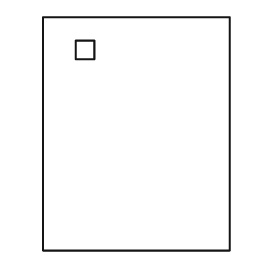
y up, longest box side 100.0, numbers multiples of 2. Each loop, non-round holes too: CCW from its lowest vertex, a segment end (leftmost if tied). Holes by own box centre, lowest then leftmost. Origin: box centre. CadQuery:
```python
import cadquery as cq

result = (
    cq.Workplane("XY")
    .moveTo(-40.0, -50.0)
    .lineTo(40.0, -50.0)
    .lineTo(40.0, 50.0)
    .lineTo(-40.0, 50.0)
    .close()
    .moveTo(-26.0, 32.0)
    .lineTo(-18.0, 32.0)
    .lineTo(-18.0, 40.0)
    .lineTo(-26.0, 40.0)
    .close()
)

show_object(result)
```